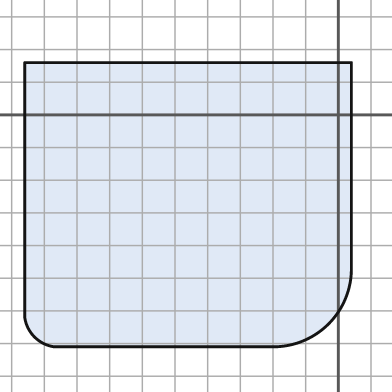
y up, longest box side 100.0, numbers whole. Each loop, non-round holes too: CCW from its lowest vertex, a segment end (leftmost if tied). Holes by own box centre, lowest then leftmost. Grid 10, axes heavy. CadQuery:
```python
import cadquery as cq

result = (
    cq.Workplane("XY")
    .moveTo(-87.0, -71.0)
    .lineTo(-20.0, -71.0)
    .threePointArc((-3.0, -64.0), (4.0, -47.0))
    .lineTo(4.0, 16.0)
    .lineTo(-96.0, 16.0)
    .lineTo(-96.0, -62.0)
    .threePointArc((-93.0, -68.0), (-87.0, -71.0))
    .close()
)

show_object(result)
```